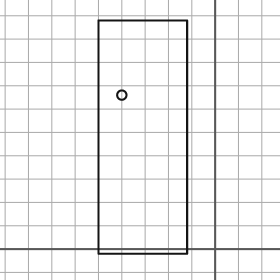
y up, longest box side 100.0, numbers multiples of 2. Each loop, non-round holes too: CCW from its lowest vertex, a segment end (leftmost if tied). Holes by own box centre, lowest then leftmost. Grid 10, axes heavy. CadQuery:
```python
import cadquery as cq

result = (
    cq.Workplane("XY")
    .moveTo(-50.0, -2.0)
    .lineTo(-12.0, -2.0)
    .lineTo(-12.0, 98.0)
    .lineTo(-50.0, 98.0)
    .close()
    .moveTo(-40.0, 66.0)
    .circle(2.0)
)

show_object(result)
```